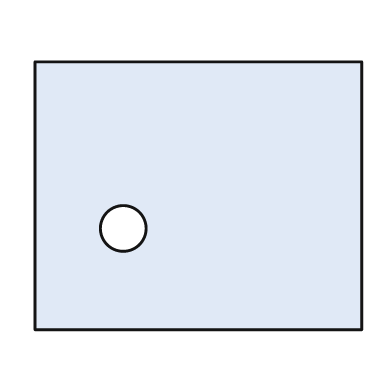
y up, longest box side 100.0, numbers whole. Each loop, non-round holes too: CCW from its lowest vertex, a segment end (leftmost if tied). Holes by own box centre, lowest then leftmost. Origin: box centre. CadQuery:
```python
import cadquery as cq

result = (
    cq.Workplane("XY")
    .moveTo(-50.0, -41.0)
    .lineTo(50.0, -41.0)
    .lineTo(50.0, 41.0)
    .lineTo(-50.0, 41.0)
    .close()
    .moveTo(-23.0, -10.0)
    .circle(7.0)
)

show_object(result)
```